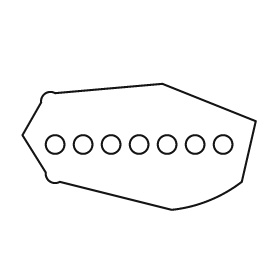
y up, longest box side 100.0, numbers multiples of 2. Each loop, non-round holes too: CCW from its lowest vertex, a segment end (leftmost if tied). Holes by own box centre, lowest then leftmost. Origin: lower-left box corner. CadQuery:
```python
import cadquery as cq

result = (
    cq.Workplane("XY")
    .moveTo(64.0, 0.0)
    .threePointArc((80.0, 4.0), (94.0, 12.0))
    .lineTo(100.0, 38.0)
    .lineTo(60.0, 54.0)
    .lineTo(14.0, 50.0)
    .threePointArc((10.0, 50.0), (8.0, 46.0))
    .lineTo(0.0, 32.0)
    .lineTo(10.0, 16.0)
    .threePointArc((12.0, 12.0), (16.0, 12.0))
    .close()
    .moveTo(14.0, 28.0)
    .circle(4.0)
    .moveTo(26.0, 28.0)
    .circle(4.0)
    .moveTo(38.0, 28.0)
    .circle(4.0)
    .moveTo(50.0, 28.0)
    .circle(4.0)
    .moveTo(62.0, 28.0)
    .circle(4.0)
    .moveTo(74.0, 28.0)
    .circle(4.0)
    .moveTo(86.0, 28.0)
    .circle(4.0)
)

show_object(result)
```